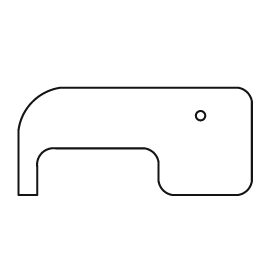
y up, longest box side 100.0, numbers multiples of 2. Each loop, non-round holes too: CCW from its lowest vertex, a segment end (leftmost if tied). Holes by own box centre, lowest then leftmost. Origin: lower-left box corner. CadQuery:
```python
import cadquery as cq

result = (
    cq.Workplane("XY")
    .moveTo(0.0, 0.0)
    .lineTo(8.0, 0.0)
    .lineTo(8.0, 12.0)
    .threePointArc((10.0, 18.0), (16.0, 20.0))
    .lineTo(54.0, 20.0)
    .threePointArc((58.0, 18.0), (60.0, 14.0))
    .lineTo(60.0, 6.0)
    .threePointArc((62.0, 2.0), (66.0, 0.0))
    .lineTo(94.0, 0.0)
    .threePointArc((98.0, 2.0), (100.0, 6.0))
    .lineTo(100.0, 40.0)
    .threePointArc((98.0, 44.0), (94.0, 46.0))
    .lineTo(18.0, 46.0)
    .threePointArc((6.0, 40.0), (0.0, 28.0))
    .close()
    .moveTo(78.0, 34.0)
    .circle(2.0)
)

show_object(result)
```